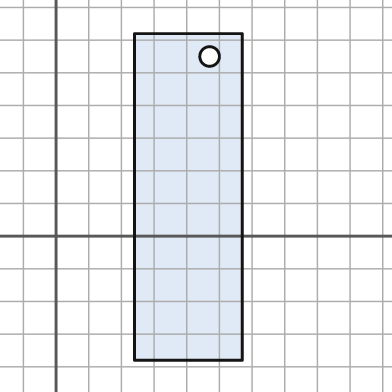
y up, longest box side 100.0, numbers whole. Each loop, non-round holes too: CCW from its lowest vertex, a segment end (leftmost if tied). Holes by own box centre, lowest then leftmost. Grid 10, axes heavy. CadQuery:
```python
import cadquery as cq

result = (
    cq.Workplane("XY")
    .moveTo(24.0, -38.0)
    .lineTo(57.0, -38.0)
    .lineTo(57.0, 62.0)
    .lineTo(24.0, 62.0)
    .close()
    .moveTo(47.0, 55.0)
    .circle(3.0)
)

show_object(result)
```